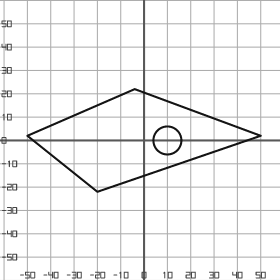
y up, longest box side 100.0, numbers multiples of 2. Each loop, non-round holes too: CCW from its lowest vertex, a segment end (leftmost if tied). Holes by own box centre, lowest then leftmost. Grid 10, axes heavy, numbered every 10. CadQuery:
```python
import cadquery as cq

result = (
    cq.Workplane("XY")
    .moveTo(-20.0, -22.0)
    .lineTo(50.0, 2.0)
    .lineTo(-4.0, 22.0)
    .lineTo(-50.0, 2.0)
    .close()
    .moveTo(10.0, 0.0)
    .circle(6.0)
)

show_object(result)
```